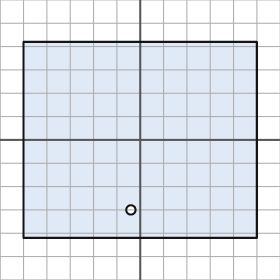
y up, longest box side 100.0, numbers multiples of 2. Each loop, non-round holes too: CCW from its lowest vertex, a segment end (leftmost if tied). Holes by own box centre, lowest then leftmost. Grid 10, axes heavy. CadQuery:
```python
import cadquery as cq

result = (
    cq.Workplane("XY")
    .moveTo(-50.0, -42.0)
    .lineTo(50.0, -42.0)
    .lineTo(50.0, 42.0)
    .lineTo(-50.0, 42.0)
    .close()
    .moveTo(-4.0, -30.0)
    .circle(2.0)
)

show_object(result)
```